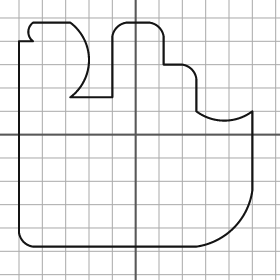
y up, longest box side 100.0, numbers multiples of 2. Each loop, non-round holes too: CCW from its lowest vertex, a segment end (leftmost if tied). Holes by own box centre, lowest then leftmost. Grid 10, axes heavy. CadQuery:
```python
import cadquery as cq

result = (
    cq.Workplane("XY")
    .moveTo(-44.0, -48.0)
    .lineTo(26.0, -48.0)
    .threePointArc((42.0, -40.0), (50.0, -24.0))
    .lineTo(50.0, 10.0)
    .threePointArc((38.0, 6.0), (26.0, 10.0))
    .lineTo(26.0, 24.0)
    .threePointArc((24.0, 28.0), (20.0, 30.0))
    .lineTo(12.0, 30.0)
    .lineTo(12.0, 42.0)
    .threePointArc((10.0, 46.0), (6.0, 48.0))
    .lineTo(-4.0, 48.0)
    .threePointArc((-8.0, 46.0), (-10.0, 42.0))
    .lineTo(-10.0, 16.0)
    .lineTo(-28.0, 16.0)
    .threePointArc((-20.0, 32.0), (-28.0, 48.0))
    .lineTo(-44.0, 48.0)
    .threePointArc((-46.0, 44.0), (-44.0, 40.0))
    .lineTo(-50.0, 40.0)
    .lineTo(-50.0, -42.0)
    .threePointArc((-48.0, -46.0), (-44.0, -48.0))
    .close()
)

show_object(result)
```